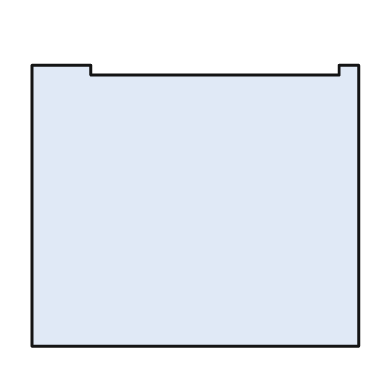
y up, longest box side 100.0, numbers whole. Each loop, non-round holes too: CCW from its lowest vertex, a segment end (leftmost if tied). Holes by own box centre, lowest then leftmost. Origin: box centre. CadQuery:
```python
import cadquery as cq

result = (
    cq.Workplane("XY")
    .moveTo(-50.0, -43.0)
    .lineTo(50.0, -43.0)
    .lineTo(50.0, 43.0)
    .lineTo(44.0, 43.0)
    .lineTo(44.0, 40.0)
    .lineTo(-32.0, 40.0)
    .lineTo(-32.0, 43.0)
    .lineTo(-50.0, 43.0)
    .close()
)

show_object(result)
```